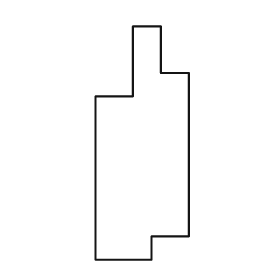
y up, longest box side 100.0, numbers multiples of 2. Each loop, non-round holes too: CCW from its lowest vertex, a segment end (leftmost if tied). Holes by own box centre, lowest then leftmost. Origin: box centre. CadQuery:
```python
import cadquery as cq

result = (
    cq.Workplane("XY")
    .moveTo(-20.0, -50.0)
    .lineTo(4.0, -50.0)
    .lineTo(4.0, -40.0)
    .lineTo(20.0, -40.0)
    .lineTo(20.0, 30.0)
    .lineTo(8.0, 30.0)
    .lineTo(8.0, 50.0)
    .lineTo(-4.0, 50.0)
    .lineTo(-4.0, 20.0)
    .lineTo(-20.0, 20.0)
    .close()
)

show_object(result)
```